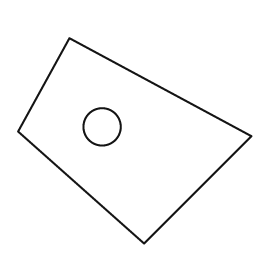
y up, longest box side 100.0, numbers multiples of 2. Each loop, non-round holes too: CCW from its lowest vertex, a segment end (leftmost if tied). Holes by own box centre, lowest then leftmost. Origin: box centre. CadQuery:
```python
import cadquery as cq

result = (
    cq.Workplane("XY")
    .moveTo(4.0, -44.0)
    .lineTo(50.0, 2.0)
    .lineTo(-28.0, 44.0)
    .lineTo(-50.0, 4.0)
    .close()
    .moveTo(-14.0, 6.0)
    .circle(8.0)
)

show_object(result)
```